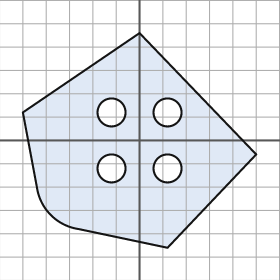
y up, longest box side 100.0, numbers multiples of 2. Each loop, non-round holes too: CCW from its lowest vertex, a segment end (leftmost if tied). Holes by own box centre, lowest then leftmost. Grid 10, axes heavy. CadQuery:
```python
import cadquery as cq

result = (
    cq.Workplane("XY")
    .moveTo(12.0, -46.0)
    .lineTo(50.0, -6.0)
    .lineTo(0.0, 46.0)
    .lineTo(-50.0, 12.0)
    .lineTo(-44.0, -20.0)
    .threePointArc((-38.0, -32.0), (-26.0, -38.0))
    .close()
    .moveTo(-12.0, -12.0)
    .circle(6.0)
    .moveTo(12.0, -12.0)
    .circle(6.0)
    .moveTo(-12.0, 12.0)
    .circle(6.0)
    .moveTo(12.0, 12.0)
    .circle(6.0)
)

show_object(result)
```